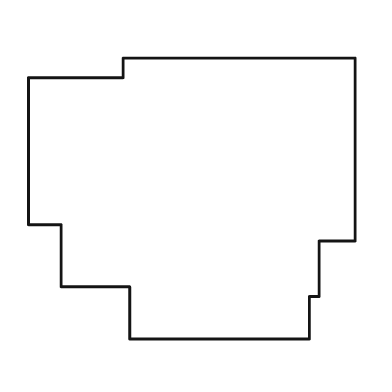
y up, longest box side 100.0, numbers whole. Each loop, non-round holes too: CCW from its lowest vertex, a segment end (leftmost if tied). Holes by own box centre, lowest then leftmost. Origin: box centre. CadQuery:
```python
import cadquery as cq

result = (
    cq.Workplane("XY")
    .moveTo(-19.0, -43.0)
    .lineTo(36.0, -43.0)
    .lineTo(36.0, -30.0)
    .lineTo(39.0, -30.0)
    .lineTo(39.0, -13.0)
    .lineTo(50.0, -13.0)
    .lineTo(50.0, 43.0)
    .lineTo(-21.0, 43.0)
    .lineTo(-21.0, 37.0)
    .lineTo(-50.0, 37.0)
    .lineTo(-50.0, -8.0)
    .lineTo(-40.0, -8.0)
    .lineTo(-40.0, -27.0)
    .lineTo(-19.0, -27.0)
    .close()
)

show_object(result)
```